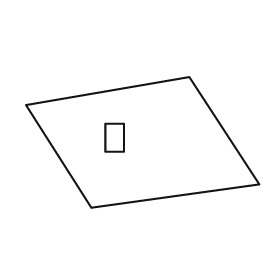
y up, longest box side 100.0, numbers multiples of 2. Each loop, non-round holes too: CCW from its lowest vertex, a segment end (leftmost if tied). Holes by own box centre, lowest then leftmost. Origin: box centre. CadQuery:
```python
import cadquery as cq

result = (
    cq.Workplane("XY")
    .moveTo(-22.0, -28.0)
    .lineTo(50.0, -18.0)
    .lineTo(20.0, 28.0)
    .lineTo(-50.0, 16.0)
    .close()
    .moveTo(-16.0, -4.0)
    .lineTo(-8.0, -4.0)
    .lineTo(-8.0, 8.0)
    .lineTo(-16.0, 8.0)
    .close()
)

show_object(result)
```